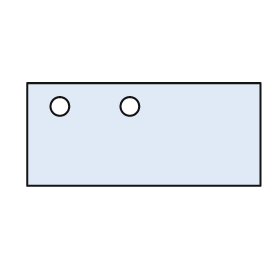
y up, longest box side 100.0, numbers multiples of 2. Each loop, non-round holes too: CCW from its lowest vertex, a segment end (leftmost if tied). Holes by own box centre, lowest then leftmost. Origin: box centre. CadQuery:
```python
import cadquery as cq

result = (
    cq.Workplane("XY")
    .moveTo(-50.0, -22.0)
    .lineTo(50.0, -22.0)
    .lineTo(50.0, 22.0)
    .lineTo(-50.0, 22.0)
    .close()
    .moveTo(-36.0, 12.0)
    .circle(4.0)
    .moveTo(-6.0, 12.0)
    .circle(4.0)
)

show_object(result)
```